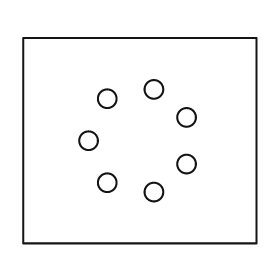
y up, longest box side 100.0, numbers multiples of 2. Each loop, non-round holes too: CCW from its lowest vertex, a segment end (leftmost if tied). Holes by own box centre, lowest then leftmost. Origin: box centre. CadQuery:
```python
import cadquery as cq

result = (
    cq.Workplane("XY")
    .moveTo(-50.0, -44.0)
    .lineTo(50.0, -44.0)
    .lineTo(50.0, 44.0)
    .lineTo(-50.0, 44.0)
    .close()
    .moveTo(6.0, -22.0)
    .circle(4.0)
    .moveTo(-14.0, -18.0)
    .circle(4.0)
    .moveTo(20.0, -10.0)
    .circle(4.0)
    .moveTo(-22.0, 0.0)
    .circle(4.0)
    .moveTo(20.0, 10.0)
    .circle(4.0)
    .moveTo(-14.0, 18.0)
    .circle(4.0)
    .moveTo(6.0, 22.0)
    .circle(4.0)
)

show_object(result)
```